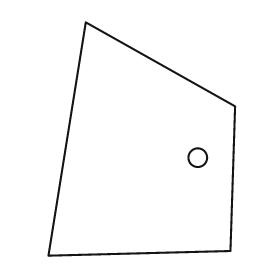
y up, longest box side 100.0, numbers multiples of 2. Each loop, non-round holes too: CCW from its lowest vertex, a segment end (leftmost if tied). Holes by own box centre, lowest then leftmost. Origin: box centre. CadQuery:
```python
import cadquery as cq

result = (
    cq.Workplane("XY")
    .moveTo(-40.0, -50.0)
    .lineTo(38.0, -48.0)
    .lineTo(40.0, 14.0)
    .lineTo(-24.0, 50.0)
    .close()
    .moveTo(24.0, -8.0)
    .circle(4.0)
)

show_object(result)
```